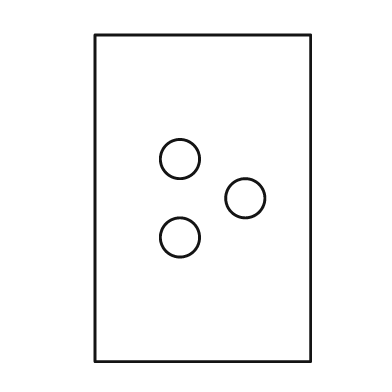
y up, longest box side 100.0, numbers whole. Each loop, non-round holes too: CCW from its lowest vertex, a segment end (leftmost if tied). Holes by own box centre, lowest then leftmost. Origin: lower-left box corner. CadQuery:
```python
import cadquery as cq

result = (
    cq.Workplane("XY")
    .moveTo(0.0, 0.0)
    .lineTo(66.0, 0.0)
    .lineTo(66.0, 100.0)
    .lineTo(0.0, 100.0)
    .close()
    .moveTo(26.0, 38.0)
    .circle(6.0)
    .moveTo(46.0, 50.0)
    .circle(6.0)
    .moveTo(26.0, 62.0)
    .circle(6.0)
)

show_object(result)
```